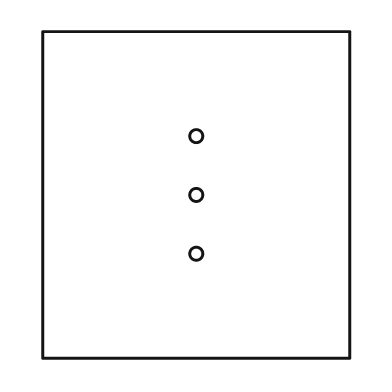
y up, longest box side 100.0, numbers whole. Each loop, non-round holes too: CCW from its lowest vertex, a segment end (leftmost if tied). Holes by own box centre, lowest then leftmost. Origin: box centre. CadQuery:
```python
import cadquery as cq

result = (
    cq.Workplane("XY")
    .moveTo(-47.0, -50.0)
    .lineTo(47.0, -50.0)
    .lineTo(47.0, 50.0)
    .lineTo(-47.0, 50.0)
    .close()
    .moveTo(0.0, -18.0)
    .circle(2.0)
    .moveTo(0.0, 0.0)
    .circle(2.0)
    .moveTo(0.0, 18.0)
    .circle(2.0)
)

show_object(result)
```